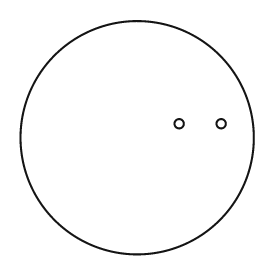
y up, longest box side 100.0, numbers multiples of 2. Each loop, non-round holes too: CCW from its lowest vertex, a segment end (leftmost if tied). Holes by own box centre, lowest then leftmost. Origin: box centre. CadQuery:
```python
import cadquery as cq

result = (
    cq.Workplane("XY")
    .moveTo(0.0, 0.0)
    .circle(50.0)
    .moveTo(18.0, 6.0)
    .circle(2.0)
    .moveTo(36.0, 6.0)
    .circle(2.0)
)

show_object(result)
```